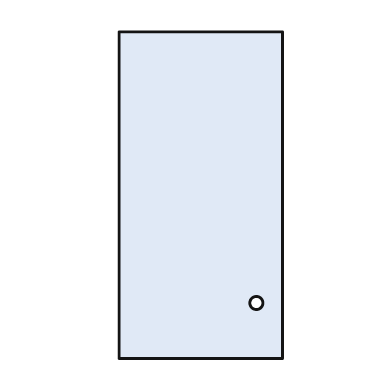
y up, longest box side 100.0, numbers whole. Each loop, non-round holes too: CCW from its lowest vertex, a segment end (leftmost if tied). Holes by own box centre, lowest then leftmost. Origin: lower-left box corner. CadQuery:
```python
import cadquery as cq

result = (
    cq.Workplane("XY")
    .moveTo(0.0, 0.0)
    .lineTo(50.0, 0.0)
    .lineTo(50.0, 100.0)
    .lineTo(0.0, 100.0)
    .close()
    .moveTo(42.0, 17.0)
    .circle(2.0)
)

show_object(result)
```